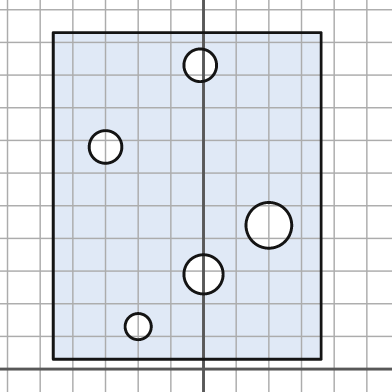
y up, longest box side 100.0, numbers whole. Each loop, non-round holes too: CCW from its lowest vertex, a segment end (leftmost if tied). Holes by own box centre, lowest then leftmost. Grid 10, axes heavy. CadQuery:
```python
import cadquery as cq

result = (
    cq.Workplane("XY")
    .moveTo(-46.0, 3.0)
    .lineTo(36.0, 3.0)
    .lineTo(36.0, 103.0)
    .lineTo(-46.0, 103.0)
    .close()
    .moveTo(-20.0, 13.0)
    .circle(4.0)
    .moveTo(0.0, 29.0)
    .circle(6.0)
    .moveTo(20.0, 44.0)
    .circle(7.0)
    .moveTo(-30.0, 68.0)
    .circle(5.0)
    .moveTo(-1.0, 93.0)
    .circle(5.0)
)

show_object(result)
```